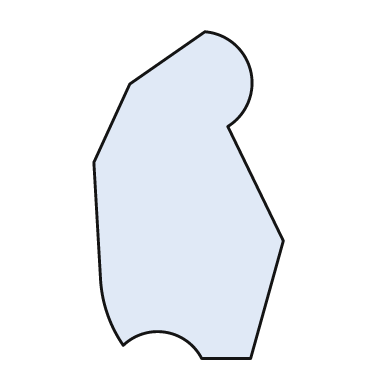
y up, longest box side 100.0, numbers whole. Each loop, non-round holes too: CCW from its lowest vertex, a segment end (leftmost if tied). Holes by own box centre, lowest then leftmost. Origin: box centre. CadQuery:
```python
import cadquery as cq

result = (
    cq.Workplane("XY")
    .moveTo(4.0, -50.0)
    .lineTo(19.0, -50.0)
    .lineTo(29.0, -14.0)
    .lineTo(12.0, 21.0)
    .threePointArc((19.0, 38.0), (5.0, 50.0))
    .lineTo(-18.0, 34.0)
    .lineTo(-29.0, 10.0)
    .lineTo(-27.0, -25.0)
    .threePointArc((-25.0, -36.0), (-20.0, -46.0))
    .threePointArc((-7.0, -42.0), (4.0, -50.0))
    .close()
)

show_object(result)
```